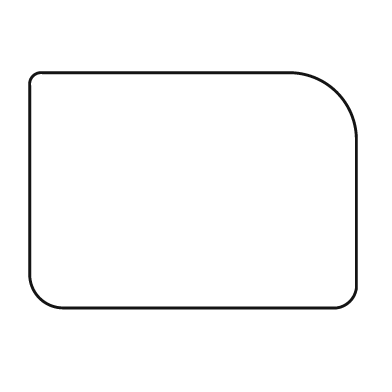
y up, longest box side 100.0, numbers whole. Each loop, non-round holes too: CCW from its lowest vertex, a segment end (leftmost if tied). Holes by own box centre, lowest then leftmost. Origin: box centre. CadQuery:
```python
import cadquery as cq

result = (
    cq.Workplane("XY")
    .moveTo(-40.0, -36.0)
    .lineTo(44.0, -36.0)
    .threePointArc((48.0, -34.0), (50.0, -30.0))
    .lineTo(50.0, 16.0)
    .threePointArc((44.0, 30.0), (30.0, 36.0))
    .lineTo(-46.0, 36.0)
    .threePointArc((-49.0, 35.0), (-50.0, 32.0))
    .lineTo(-50.0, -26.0)
    .threePointArc((-47.0, -33.0), (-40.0, -36.0))
    .close()
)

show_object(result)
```